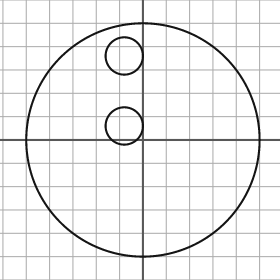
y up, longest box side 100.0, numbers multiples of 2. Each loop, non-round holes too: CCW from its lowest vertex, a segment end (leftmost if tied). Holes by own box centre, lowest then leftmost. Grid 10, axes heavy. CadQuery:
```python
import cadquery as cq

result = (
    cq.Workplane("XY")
    .moveTo(0.0, 0.0)
    .circle(50.0)
    .moveTo(-8.0, 6.0)
    .circle(8.0)
    .moveTo(-8.0, 36.0)
    .circle(8.0)
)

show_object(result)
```